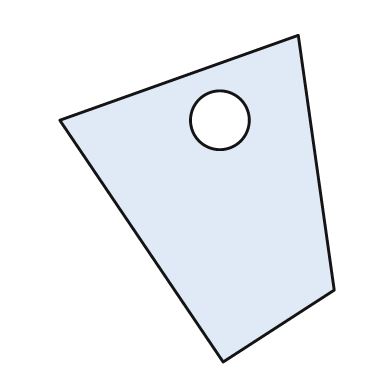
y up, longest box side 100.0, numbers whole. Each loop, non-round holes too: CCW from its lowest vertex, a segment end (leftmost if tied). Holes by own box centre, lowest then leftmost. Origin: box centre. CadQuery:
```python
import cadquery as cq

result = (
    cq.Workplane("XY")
    .moveTo(8.0, -50.0)
    .lineTo(42.0, -28.0)
    .lineTo(31.0, 50.0)
    .lineTo(-42.0, 24.0)
    .close()
    .moveTo(7.0, 24.0)
    .circle(9.0)
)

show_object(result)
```